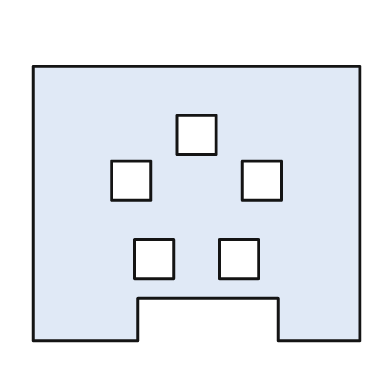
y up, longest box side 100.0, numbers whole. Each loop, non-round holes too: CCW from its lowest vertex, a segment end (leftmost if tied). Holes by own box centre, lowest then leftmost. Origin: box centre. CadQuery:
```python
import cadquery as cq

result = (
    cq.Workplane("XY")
    .moveTo(-50.0, -42.0)
    .lineTo(-18.0, -42.0)
    .lineTo(-18.0, -29.0)
    .lineTo(25.0, -29.0)
    .lineTo(25.0, -42.0)
    .lineTo(50.0, -42.0)
    .lineTo(50.0, 42.0)
    .lineTo(-50.0, 42.0)
    .close()
    .moveTo(-19.0, -23.0)
    .lineTo(-7.0, -23.0)
    .lineTo(-7.0, -11.0)
    .lineTo(-19.0, -11.0)
    .close()
    .moveTo(7.0, -23.0)
    .lineTo(19.0, -23.0)
    .lineTo(19.0, -11.0)
    .lineTo(7.0, -11.0)
    .close()
    .moveTo(-26.0, 1.0)
    .lineTo(-14.0, 1.0)
    .lineTo(-14.0, 13.0)
    .lineTo(-26.0, 13.0)
    .close()
    .moveTo(14.0, 1.0)
    .lineTo(26.0, 1.0)
    .lineTo(26.0, 13.0)
    .lineTo(14.0, 13.0)
    .close()
    .moveTo(-6.0, 15.0)
    .lineTo(6.0, 15.0)
    .lineTo(6.0, 27.0)
    .lineTo(-6.0, 27.0)
    .close()
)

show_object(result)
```